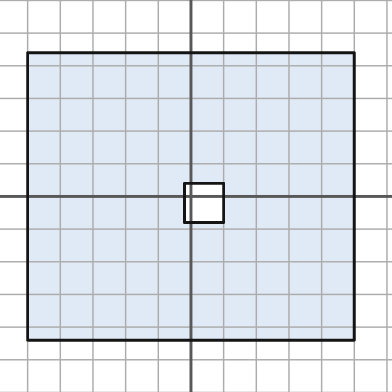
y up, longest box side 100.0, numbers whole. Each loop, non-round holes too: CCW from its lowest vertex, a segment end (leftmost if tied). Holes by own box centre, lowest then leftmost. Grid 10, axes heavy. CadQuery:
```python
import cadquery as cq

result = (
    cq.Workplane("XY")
    .moveTo(-50.0, -44.0)
    .lineTo(50.0, -44.0)
    .lineTo(50.0, 44.0)
    .lineTo(-50.0, 44.0)
    .close()
    .moveTo(-2.0, -8.0)
    .lineTo(10.0, -8.0)
    .lineTo(10.0, 4.0)
    .lineTo(-2.0, 4.0)
    .close()
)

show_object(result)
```